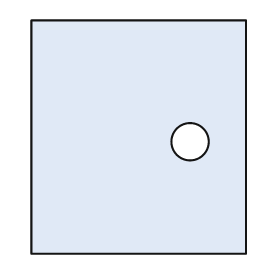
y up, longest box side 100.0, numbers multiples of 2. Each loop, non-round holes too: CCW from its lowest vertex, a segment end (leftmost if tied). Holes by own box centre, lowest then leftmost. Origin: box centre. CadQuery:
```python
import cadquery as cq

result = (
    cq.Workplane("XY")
    .moveTo(-46.0, -50.0)
    .lineTo(46.0, -50.0)
    .lineTo(46.0, 50.0)
    .lineTo(-46.0, 50.0)
    .close()
    .moveTo(22.0, -2.0)
    .circle(8.0)
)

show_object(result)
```